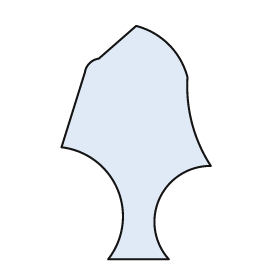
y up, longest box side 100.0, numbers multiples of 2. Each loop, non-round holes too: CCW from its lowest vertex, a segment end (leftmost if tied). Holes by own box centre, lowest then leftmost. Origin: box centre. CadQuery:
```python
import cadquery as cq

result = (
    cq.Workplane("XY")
    .moveTo(-12.0, -50.0)
    .lineTo(14.0, -50.0)
    .threePointArc((10.0, -24.0), (32.0, -10.0))
    .threePointArc((24.0, 8.0), (22.0, 28.0))
    .threePointArc((14.0, 42.0), (0.0, 50.0))
    .lineTo(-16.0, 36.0)
    .threePointArc((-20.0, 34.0), (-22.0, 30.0))
    .lineTo(-32.0, -2.0)
    .threePointArc((-8.0, -20.0), (-12.0, -50.0))
    .close()
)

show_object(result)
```